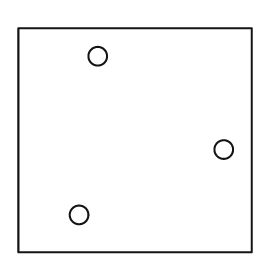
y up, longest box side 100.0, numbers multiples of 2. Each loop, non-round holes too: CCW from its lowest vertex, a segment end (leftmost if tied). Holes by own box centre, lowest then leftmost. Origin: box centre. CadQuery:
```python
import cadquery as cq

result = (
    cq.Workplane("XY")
    .moveTo(-50.0, -48.0)
    .lineTo(50.0, -48.0)
    .lineTo(50.0, 48.0)
    .lineTo(-50.0, 48.0)
    .close()
    .moveTo(-24.0, -32.0)
    .circle(4.0)
    .moveTo(38.0, -4.0)
    .circle(4.0)
    .moveTo(-16.0, 36.0)
    .circle(4.0)
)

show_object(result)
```